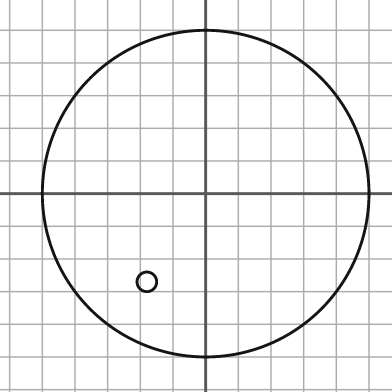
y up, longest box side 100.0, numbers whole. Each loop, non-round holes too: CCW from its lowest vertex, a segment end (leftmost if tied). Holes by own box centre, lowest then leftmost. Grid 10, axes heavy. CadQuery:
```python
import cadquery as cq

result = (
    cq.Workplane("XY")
    .moveTo(0.0, 0.0)
    .circle(50.0)
    .moveTo(-18.0, -27.0)
    .circle(3.0)
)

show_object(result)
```